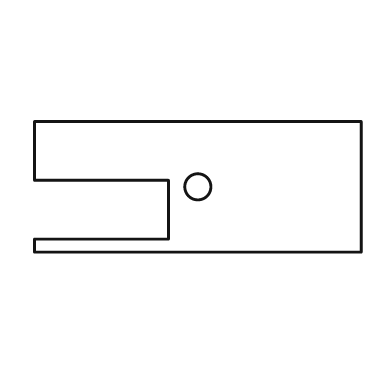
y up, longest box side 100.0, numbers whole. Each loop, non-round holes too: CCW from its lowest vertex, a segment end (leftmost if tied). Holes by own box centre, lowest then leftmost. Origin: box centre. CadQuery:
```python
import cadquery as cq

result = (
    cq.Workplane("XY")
    .moveTo(-50.0, -20.0)
    .lineTo(50.0, -20.0)
    .lineTo(50.0, 20.0)
    .lineTo(-50.0, 20.0)
    .lineTo(-50.0, 2.0)
    .lineTo(-9.0, 2.0)
    .lineTo(-9.0, -16.0)
    .lineTo(-50.0, -16.0)
    .close()
    .moveTo(0.0, 0.0)
    .circle(4.0)
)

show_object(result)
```